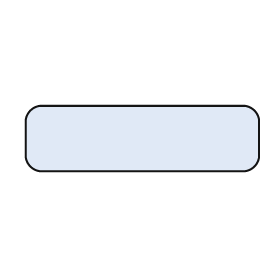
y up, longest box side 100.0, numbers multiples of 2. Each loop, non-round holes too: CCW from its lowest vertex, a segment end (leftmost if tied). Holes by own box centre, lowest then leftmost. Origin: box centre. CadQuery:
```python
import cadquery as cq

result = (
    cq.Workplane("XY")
    .moveTo(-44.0, -14.0)
    .lineTo(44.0, -14.0)
    .threePointArc((48.0, -12.0), (50.0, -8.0))
    .lineTo(50.0, 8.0)
    .threePointArc((48.0, 12.0), (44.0, 14.0))
    .lineTo(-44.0, 14.0)
    .threePointArc((-48.0, 12.0), (-50.0, 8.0))
    .lineTo(-50.0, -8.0)
    .threePointArc((-48.0, -12.0), (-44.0, -14.0))
    .close()
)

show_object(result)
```